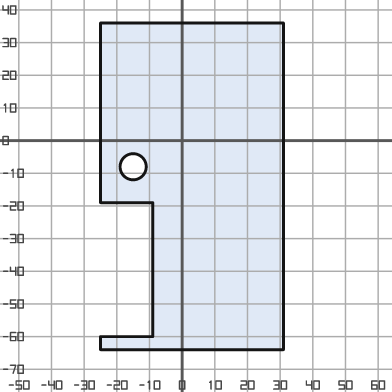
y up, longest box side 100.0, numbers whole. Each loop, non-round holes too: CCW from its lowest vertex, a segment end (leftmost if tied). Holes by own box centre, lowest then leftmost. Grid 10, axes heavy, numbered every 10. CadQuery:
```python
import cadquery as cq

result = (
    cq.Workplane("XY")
    .moveTo(-25.0, -64.0)
    .lineTo(31.0, -64.0)
    .lineTo(31.0, 36.0)
    .lineTo(-25.0, 36.0)
    .lineTo(-25.0, -19.0)
    .lineTo(-9.0, -19.0)
    .lineTo(-9.0, -60.0)
    .lineTo(-25.0, -60.0)
    .close()
    .moveTo(-15.0, -8.0)
    .circle(4.0)
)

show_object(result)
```